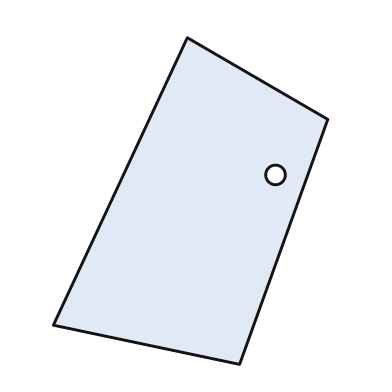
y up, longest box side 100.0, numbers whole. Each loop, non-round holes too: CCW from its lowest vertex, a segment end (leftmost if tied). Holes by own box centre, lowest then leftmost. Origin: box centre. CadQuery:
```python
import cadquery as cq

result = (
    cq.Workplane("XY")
    .moveTo(15.0, -50.0)
    .lineTo(42.0, 25.0)
    .lineTo(-1.0, 50.0)
    .lineTo(-42.0, -38.0)
    .close()
    .moveTo(26.0, 8.0)
    .circle(3.0)
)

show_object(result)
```